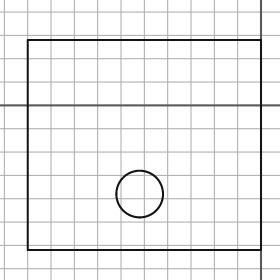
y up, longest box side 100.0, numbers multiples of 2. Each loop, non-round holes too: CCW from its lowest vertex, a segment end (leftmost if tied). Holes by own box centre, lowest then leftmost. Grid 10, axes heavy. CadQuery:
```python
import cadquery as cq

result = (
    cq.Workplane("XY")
    .moveTo(-100.0, -62.0)
    .lineTo(0.0, -62.0)
    .lineTo(0.0, 28.0)
    .lineTo(-100.0, 28.0)
    .close()
    .moveTo(-52.0, -38.0)
    .circle(10.0)
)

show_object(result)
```